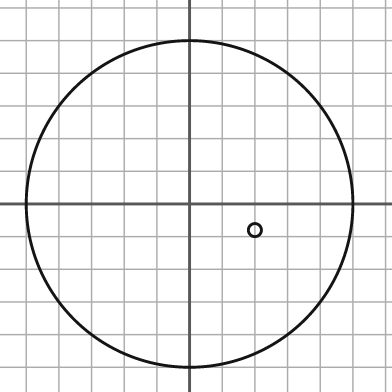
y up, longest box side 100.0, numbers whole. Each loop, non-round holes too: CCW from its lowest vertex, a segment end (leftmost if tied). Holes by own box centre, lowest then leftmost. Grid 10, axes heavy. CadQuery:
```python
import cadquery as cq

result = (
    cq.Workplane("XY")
    .moveTo(0.0, 0.0)
    .circle(50.0)
    .moveTo(20.0, -8.0)
    .circle(2.0)
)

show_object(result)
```